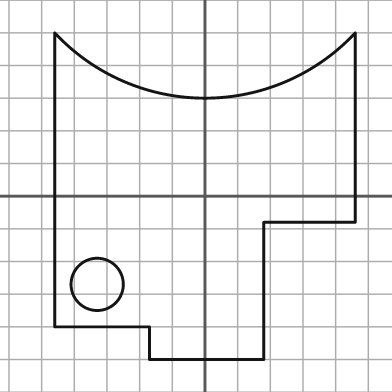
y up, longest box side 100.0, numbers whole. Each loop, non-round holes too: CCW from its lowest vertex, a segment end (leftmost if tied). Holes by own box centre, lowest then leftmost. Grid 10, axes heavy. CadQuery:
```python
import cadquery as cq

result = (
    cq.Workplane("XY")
    .moveTo(-17.0, -50.0)
    .lineTo(18.0, -50.0)
    .lineTo(18.0, -8.0)
    .lineTo(46.0, -8.0)
    .lineTo(46.0, 50.0)
    .threePointArc((0.0, 30.0), (-46.0, 50.0))
    .lineTo(-46.0, -40.0)
    .lineTo(-17.0, -40.0)
    .close()
    .moveTo(-33.0, -27.0)
    .circle(8.0)
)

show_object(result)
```